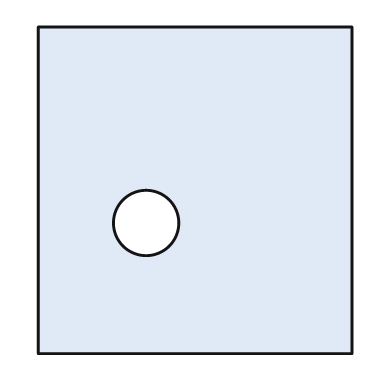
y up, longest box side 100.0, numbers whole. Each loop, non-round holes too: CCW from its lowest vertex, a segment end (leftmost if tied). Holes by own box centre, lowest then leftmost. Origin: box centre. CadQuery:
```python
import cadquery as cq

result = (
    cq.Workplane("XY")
    .moveTo(-48.0, -50.0)
    .lineTo(48.0, -50.0)
    .lineTo(48.0, 50.0)
    .lineTo(-48.0, 50.0)
    .close()
    .moveTo(-15.0, -10.0)
    .circle(10.0)
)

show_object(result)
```